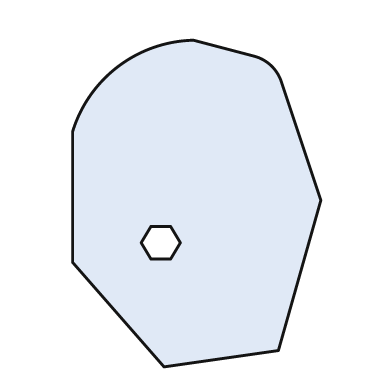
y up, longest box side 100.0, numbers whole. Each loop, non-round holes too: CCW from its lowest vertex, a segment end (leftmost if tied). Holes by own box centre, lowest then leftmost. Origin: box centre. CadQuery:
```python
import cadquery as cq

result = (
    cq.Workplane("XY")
    .moveTo(-10.0, -50.0)
    .lineTo(25.0, -45.0)
    .lineTo(38.0, 1.0)
    .lineTo(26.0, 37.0)
    .threePointArc((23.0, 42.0), (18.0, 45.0))
    .lineTo(-1.0, 50.0)
    .threePointArc((-24.0, 42.0), (-38.0, 22.0))
    .lineTo(-38.0, -18.0)
    .close()
    .moveTo(-14.0, -17.0)
    .lineTo(-8.0, -17.0)
    .lineTo(-5.0, -12.0)
    .lineTo(-8.0, -7.0)
    .lineTo(-14.0, -7.0)
    .lineTo(-17.0, -12.0)
    .close()
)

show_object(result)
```